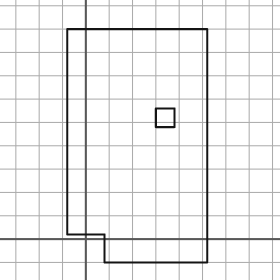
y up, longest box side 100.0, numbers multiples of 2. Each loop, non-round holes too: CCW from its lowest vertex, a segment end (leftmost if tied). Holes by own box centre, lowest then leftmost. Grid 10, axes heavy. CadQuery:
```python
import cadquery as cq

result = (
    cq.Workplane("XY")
    .moveTo(8.0, -10.0)
    .lineTo(52.0, -10.0)
    .lineTo(52.0, 90.0)
    .lineTo(-8.0, 90.0)
    .lineTo(-8.0, 2.0)
    .lineTo(8.0, 2.0)
    .close()
    .moveTo(30.0, 48.0)
    .lineTo(38.0, 48.0)
    .lineTo(38.0, 56.0)
    .lineTo(30.0, 56.0)
    .close()
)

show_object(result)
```